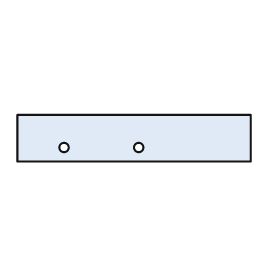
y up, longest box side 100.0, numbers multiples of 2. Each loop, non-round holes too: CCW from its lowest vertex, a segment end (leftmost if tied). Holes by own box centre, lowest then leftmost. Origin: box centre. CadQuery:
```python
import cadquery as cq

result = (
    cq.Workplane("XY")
    .moveTo(-50.0, -10.0)
    .lineTo(50.0, -10.0)
    .lineTo(50.0, 10.0)
    .lineTo(-50.0, 10.0)
    .close()
    .moveTo(-30.0, -4.0)
    .circle(2.0)
    .moveTo(2.0, -4.0)
    .circle(2.0)
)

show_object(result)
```